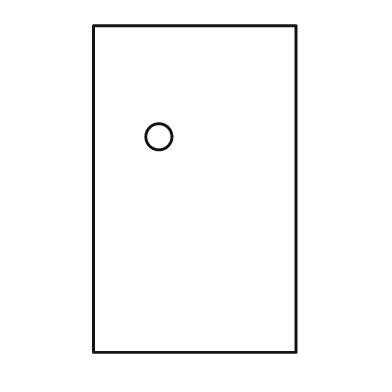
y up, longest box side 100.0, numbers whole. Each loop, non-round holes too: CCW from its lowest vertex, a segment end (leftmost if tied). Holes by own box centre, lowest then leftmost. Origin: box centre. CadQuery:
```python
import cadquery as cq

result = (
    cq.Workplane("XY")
    .moveTo(-31.0, -50.0)
    .lineTo(31.0, -50.0)
    .lineTo(31.0, 50.0)
    .lineTo(-31.0, 50.0)
    .close()
    .moveTo(-11.0, 16.0)
    .circle(4.0)
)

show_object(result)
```